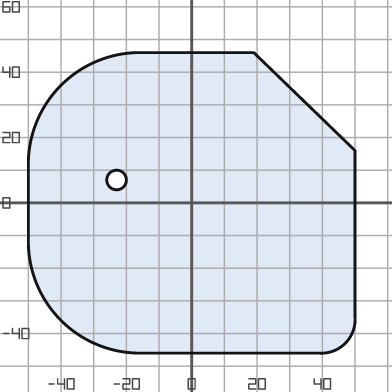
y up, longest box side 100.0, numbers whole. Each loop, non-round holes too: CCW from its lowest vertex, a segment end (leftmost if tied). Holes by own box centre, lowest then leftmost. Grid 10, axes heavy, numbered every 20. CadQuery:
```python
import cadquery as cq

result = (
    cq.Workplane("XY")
    .moveTo(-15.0, -46.0)
    .lineTo(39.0, -46.0)
    .threePointArc((47.0, -43.0), (50.0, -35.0))
    .lineTo(50.0, 16.0)
    .lineTo(19.0, 46.0)
    .lineTo(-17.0, 46.0)
    .threePointArc((-40.0, 36.0), (-50.0, 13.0))
    .lineTo(-50.0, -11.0)
    .threePointArc((-40.0, -36.0), (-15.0, -46.0))
    .close()
    .moveTo(-23.0, 7.0)
    .circle(3.0)
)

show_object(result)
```